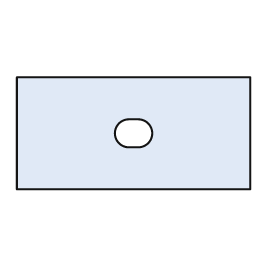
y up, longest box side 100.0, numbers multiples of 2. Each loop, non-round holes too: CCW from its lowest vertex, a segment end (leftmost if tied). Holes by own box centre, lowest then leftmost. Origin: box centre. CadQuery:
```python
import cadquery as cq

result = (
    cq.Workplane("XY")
    .moveTo(-50.0, -24.0)
    .lineTo(50.0, -24.0)
    .lineTo(50.0, 24.0)
    .lineTo(-50.0, 24.0)
    .close()
    .moveTo(-2.0, -6.0)
    .lineTo(2.0, -6.0)
    .threePointArc((8.0, 0.0), (2.0, 6.0))
    .lineTo(-2.0, 6.0)
    .threePointArc((-8.0, 0.0), (-2.0, -6.0))
    .close()
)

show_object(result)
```